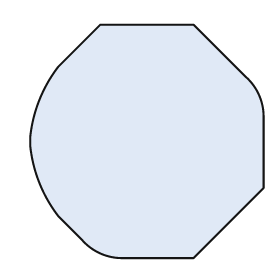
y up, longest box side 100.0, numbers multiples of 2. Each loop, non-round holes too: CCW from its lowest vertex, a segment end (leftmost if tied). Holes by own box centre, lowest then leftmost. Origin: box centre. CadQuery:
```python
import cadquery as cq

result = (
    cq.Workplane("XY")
    .moveTo(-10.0, -50.0)
    .lineTo(20.0, -50.0)
    .lineTo(50.0, -20.0)
    .lineTo(50.0, 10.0)
    .threePointArc((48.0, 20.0), (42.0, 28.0))
    .lineTo(20.0, 50.0)
    .lineTo(-20.0, 50.0)
    .lineTo(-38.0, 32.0)
    .threePointArc((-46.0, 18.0), (-50.0, 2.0))
    .lineTo(-50.0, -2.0)
    .threePointArc((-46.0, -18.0), (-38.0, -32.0))
    .lineTo(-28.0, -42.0)
    .threePointArc((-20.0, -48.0), (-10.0, -50.0))
    .close()
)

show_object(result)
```